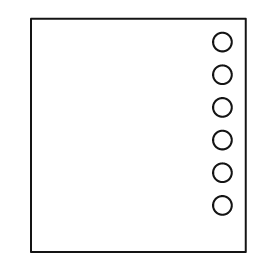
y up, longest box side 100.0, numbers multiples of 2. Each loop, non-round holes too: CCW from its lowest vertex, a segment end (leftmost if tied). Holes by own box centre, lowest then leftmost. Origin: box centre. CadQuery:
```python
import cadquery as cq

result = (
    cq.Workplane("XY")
    .moveTo(-46.0, -50.0)
    .lineTo(46.0, -50.0)
    .lineTo(46.0, 50.0)
    .lineTo(-46.0, 50.0)
    .close()
    .moveTo(36.0, -30.0)
    .circle(4.0)
    .moveTo(36.0, -16.0)
    .circle(4.0)
    .moveTo(36.0, -2.0)
    .circle(4.0)
    .moveTo(36.0, 12.0)
    .circle(4.0)
    .moveTo(36.0, 26.0)
    .circle(4.0)
    .moveTo(36.0, 40.0)
    .circle(4.0)
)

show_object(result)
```